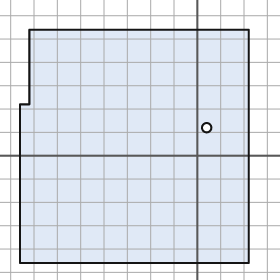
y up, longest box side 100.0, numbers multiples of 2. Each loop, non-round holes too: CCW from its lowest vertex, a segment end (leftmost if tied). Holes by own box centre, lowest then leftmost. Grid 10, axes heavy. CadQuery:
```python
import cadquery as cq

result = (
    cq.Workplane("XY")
    .moveTo(-76.0, -46.0)
    .lineTo(22.0, -46.0)
    .lineTo(22.0, 54.0)
    .lineTo(-72.0, 54.0)
    .lineTo(-72.0, 22.0)
    .lineTo(-76.0, 22.0)
    .close()
    .moveTo(4.0, 12.0)
    .circle(2.0)
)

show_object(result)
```